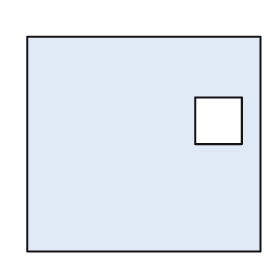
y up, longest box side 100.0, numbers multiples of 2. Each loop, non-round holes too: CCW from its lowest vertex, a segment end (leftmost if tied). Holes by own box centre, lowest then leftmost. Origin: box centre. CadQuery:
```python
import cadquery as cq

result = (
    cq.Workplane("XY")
    .moveTo(-50.0, -46.0)
    .lineTo(50.0, -46.0)
    .lineTo(50.0, 46.0)
    .lineTo(-50.0, 46.0)
    .close()
    .moveTo(22.0, 0.0)
    .lineTo(42.0, 0.0)
    .lineTo(42.0, 20.0)
    .lineTo(22.0, 20.0)
    .close()
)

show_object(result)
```